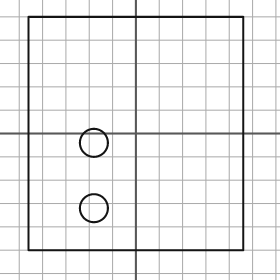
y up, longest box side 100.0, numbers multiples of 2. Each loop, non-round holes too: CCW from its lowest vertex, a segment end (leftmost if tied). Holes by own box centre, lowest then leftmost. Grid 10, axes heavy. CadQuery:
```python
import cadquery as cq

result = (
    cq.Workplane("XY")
    .moveTo(-46.0, -50.0)
    .lineTo(46.0, -50.0)
    .lineTo(46.0, 50.0)
    .lineTo(-46.0, 50.0)
    .close()
    .moveTo(-18.0, -32.0)
    .circle(6.0)
    .moveTo(-18.0, -4.0)
    .circle(6.0)
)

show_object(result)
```